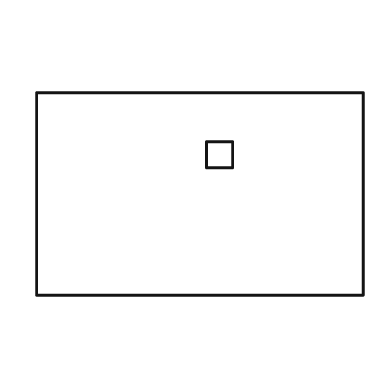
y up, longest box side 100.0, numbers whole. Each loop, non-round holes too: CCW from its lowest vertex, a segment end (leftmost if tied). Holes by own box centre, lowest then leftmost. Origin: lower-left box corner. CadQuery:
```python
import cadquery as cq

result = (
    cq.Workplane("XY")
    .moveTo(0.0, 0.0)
    .lineTo(100.0, 0.0)
    .lineTo(100.0, 62.0)
    .lineTo(0.0, 62.0)
    .close()
    .moveTo(52.0, 39.0)
    .lineTo(60.0, 39.0)
    .lineTo(60.0, 47.0)
    .lineTo(52.0, 47.0)
    .close()
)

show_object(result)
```